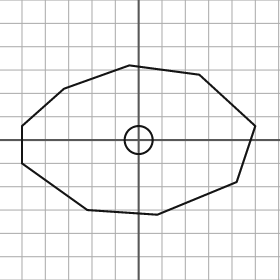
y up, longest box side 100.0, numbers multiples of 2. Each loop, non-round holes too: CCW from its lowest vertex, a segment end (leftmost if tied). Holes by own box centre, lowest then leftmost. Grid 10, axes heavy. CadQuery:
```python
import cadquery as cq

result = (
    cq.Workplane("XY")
    .moveTo(8.0, -32.0)
    .lineTo(42.0, -18.0)
    .lineTo(50.0, 6.0)
    .lineTo(26.0, 28.0)
    .lineTo(-4.0, 32.0)
    .lineTo(-32.0, 22.0)
    .lineTo(-50.0, 6.0)
    .lineTo(-50.0, -10.0)
    .lineTo(-22.0, -30.0)
    .close()
    .moveTo(0.0, 0.0)
    .circle(6.0)
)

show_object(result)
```